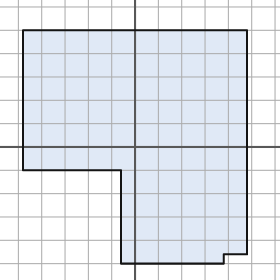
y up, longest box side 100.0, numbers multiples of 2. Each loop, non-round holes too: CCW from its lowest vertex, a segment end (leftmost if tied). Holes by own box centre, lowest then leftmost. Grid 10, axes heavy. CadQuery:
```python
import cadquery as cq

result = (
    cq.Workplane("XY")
    .moveTo(-6.0, -50.0)
    .lineTo(38.0, -50.0)
    .lineTo(38.0, -46.0)
    .lineTo(48.0, -46.0)
    .lineTo(48.0, 50.0)
    .lineTo(-48.0, 50.0)
    .lineTo(-48.0, -10.0)
    .lineTo(-6.0, -10.0)
    .close()
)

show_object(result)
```